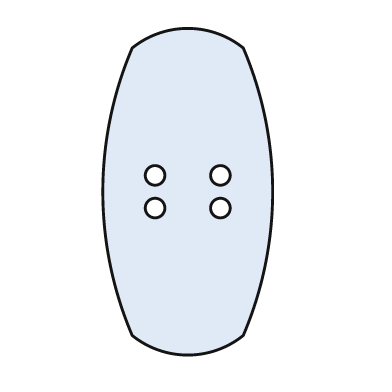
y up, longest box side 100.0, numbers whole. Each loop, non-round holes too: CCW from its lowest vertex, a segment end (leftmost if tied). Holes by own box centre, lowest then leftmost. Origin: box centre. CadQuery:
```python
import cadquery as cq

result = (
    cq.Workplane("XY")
    .moveTo(-17.0, -44.0)
    .threePointArc((0.0, -50.0), (17.0, -44.0))
    .threePointArc((26.0, 0.0), (17.0, 44.0))
    .threePointArc((0.0, 50.0), (-17.0, 44.0))
    .threePointArc((-26.0, 0.0), (-17.0, -44.0))
    .close()
    .moveTo(-10.0, -5.0)
    .circle(3.0)
    .moveTo(10.0, -5.0)
    .circle(3.0)
    .moveTo(-10.0, 5.0)
    .circle(3.0)
    .moveTo(10.0, 5.0)
    .circle(3.0)
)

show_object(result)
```